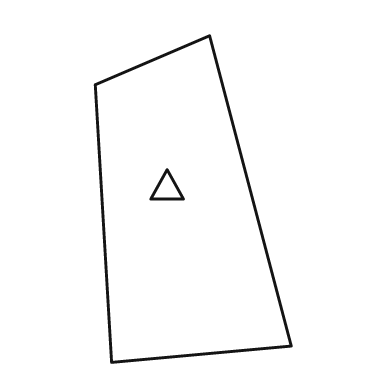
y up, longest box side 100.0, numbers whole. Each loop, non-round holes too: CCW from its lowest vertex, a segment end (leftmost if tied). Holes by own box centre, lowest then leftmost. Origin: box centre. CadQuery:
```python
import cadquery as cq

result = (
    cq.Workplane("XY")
    .moveTo(-25.0, -50.0)
    .lineTo(30.0, -45.0)
    .lineTo(5.0, 50.0)
    .lineTo(-30.0, 35.0)
    .close()
    .moveTo(-13.0, 0.0)
    .lineTo(-3.0, 0.0)
    .lineTo(-8.0, 9.0)
    .close()
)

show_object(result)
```